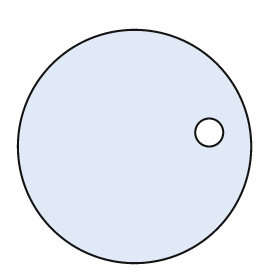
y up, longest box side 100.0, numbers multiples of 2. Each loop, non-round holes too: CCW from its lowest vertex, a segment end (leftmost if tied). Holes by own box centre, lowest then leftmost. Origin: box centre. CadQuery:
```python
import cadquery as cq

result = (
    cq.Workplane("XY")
    .moveTo(0.0, 0.0)
    .circle(50.0)
    .moveTo(32.0, 6.0)
    .circle(6.0)
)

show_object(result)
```